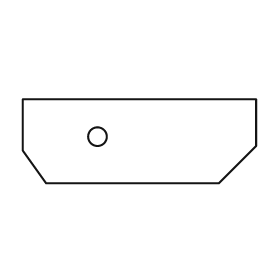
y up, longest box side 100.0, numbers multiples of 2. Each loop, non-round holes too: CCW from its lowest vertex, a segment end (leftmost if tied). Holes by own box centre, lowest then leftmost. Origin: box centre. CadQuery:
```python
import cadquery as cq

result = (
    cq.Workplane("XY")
    .moveTo(-40.0, -18.0)
    .lineTo(34.0, -18.0)
    .lineTo(50.0, -2.0)
    .lineTo(50.0, 18.0)
    .lineTo(-50.0, 18.0)
    .lineTo(-50.0, -4.0)
    .close()
    .moveTo(-18.0, 2.0)
    .circle(4.0)
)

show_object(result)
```